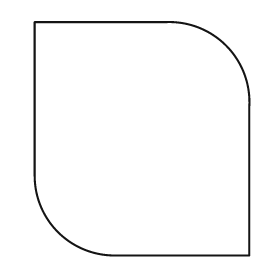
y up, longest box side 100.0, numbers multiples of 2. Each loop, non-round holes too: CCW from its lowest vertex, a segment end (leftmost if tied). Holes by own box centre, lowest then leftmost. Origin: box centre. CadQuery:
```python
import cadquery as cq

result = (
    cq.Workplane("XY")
    .moveTo(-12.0, -50.0)
    .lineTo(46.0, -50.0)
    .lineTo(46.0, 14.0)
    .threePointArc((36.0, 40.0), (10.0, 50.0))
    .lineTo(-46.0, 50.0)
    .lineTo(-46.0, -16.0)
    .threePointArc((-36.0, -40.0), (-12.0, -50.0))
    .close()
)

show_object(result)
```